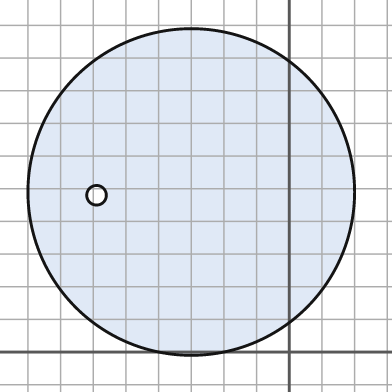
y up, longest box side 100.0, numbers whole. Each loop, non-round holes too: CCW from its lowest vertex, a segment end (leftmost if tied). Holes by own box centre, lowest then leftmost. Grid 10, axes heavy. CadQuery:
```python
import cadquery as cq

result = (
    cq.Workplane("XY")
    .moveTo(-30.0, 49.0)
    .circle(50.0)
    .moveTo(-59.0, 48.0)
    .circle(3.0)
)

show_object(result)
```